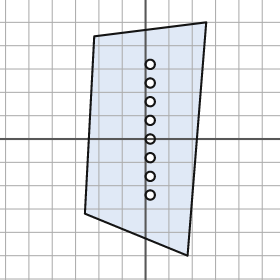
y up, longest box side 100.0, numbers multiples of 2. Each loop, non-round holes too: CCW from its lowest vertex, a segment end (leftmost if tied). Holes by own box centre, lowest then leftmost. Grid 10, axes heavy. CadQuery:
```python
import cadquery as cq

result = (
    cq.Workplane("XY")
    .moveTo(18.0, -50.0)
    .lineTo(26.0, 50.0)
    .lineTo(-22.0, 44.0)
    .lineTo(-26.0, -32.0)
    .close()
    .moveTo(2.0, -24.0)
    .circle(2.0)
    .moveTo(2.0, -16.0)
    .circle(2.0)
    .moveTo(2.0, -8.0)
    .circle(2.0)
    .moveTo(2.0, 0.0)
    .circle(2.0)
    .moveTo(2.0, 8.0)
    .circle(2.0)
    .moveTo(2.0, 16.0)
    .circle(2.0)
    .moveTo(2.0, 24.0)
    .circle(2.0)
    .moveTo(2.0, 32.0)
    .circle(2.0)
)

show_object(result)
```